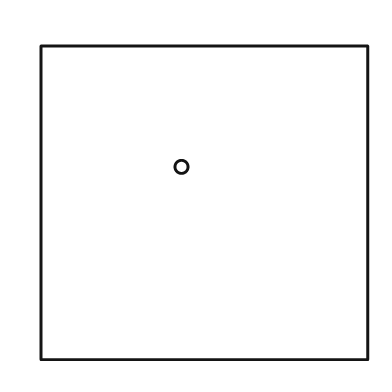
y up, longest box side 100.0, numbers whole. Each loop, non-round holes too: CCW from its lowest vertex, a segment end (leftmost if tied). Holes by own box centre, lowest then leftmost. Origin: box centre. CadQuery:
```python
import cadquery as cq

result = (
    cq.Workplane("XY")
    .moveTo(-50.0, -48.0)
    .lineTo(50.0, -48.0)
    .lineTo(50.0, 48.0)
    .lineTo(-50.0, 48.0)
    .close()
    .moveTo(-7.0, 11.0)
    .circle(2.0)
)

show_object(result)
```